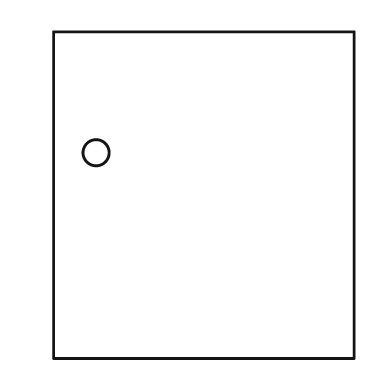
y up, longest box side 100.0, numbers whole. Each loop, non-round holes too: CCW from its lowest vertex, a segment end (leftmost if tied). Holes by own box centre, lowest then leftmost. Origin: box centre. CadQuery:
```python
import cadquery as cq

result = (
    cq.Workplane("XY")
    .moveTo(-46.0, -50.0)
    .lineTo(46.0, -50.0)
    .lineTo(46.0, 50.0)
    .lineTo(-46.0, 50.0)
    .close()
    .moveTo(-33.0, 13.0)
    .circle(4.0)
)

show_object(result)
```